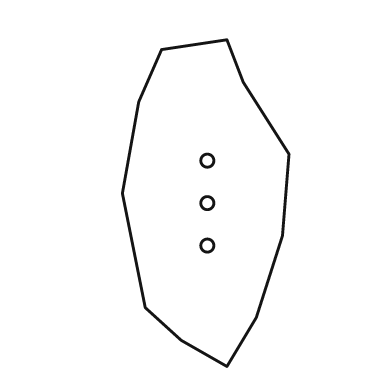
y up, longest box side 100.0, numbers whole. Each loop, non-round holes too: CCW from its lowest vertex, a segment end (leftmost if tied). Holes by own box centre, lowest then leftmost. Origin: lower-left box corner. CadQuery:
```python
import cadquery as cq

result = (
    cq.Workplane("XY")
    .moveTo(32.0, 0.0)
    .lineTo(41.0, 15.0)
    .lineTo(49.0, 40.0)
    .lineTo(51.0, 65.0)
    .lineTo(37.0, 87.0)
    .lineTo(32.0, 100.0)
    .lineTo(12.0, 97.0)
    .lineTo(5.0, 81.0)
    .lineTo(0.0, 53.0)
    .lineTo(7.0, 18.0)
    .lineTo(18.0, 8.0)
    .close()
    .moveTo(26.0, 37.0)
    .circle(2.0)
    .moveTo(26.0, 50.0)
    .circle(2.0)
    .moveTo(26.0, 63.0)
    .circle(2.0)
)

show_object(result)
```